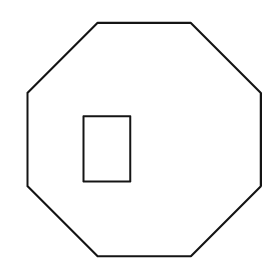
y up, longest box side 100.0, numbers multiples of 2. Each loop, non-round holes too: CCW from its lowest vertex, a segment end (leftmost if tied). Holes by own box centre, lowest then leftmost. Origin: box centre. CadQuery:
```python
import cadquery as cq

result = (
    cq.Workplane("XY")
    .moveTo(-20.0, -50.0)
    .lineTo(20.0, -50.0)
    .lineTo(50.0, -20.0)
    .lineTo(50.0, 20.0)
    .lineTo(20.0, 50.0)
    .lineTo(-20.0, 50.0)
    .lineTo(-50.0, 20.0)
    .lineTo(-50.0, -20.0)
    .close()
    .moveTo(-26.0, -18.0)
    .lineTo(-6.0, -18.0)
    .lineTo(-6.0, 10.0)
    .lineTo(-26.0, 10.0)
    .close()
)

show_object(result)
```